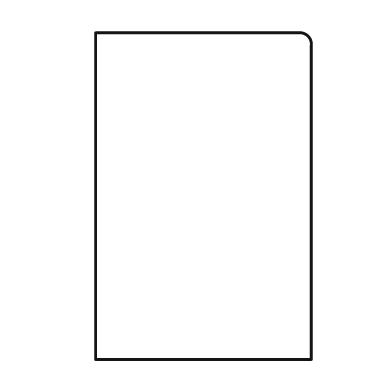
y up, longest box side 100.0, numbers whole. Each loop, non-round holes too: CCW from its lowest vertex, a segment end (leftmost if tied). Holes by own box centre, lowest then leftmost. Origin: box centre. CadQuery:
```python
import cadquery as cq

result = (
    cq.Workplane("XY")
    .moveTo(-33.0, -50.0)
    .lineTo(33.0, -50.0)
    .lineTo(33.0, 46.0)
    .threePointArc((32.0, 49.0), (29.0, 50.0))
    .lineTo(-33.0, 50.0)
    .close()
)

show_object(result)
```